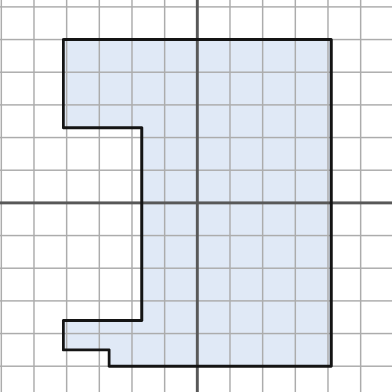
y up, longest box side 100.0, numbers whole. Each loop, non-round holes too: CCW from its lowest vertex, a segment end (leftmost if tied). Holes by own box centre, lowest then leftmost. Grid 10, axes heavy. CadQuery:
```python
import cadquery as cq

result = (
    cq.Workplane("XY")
    .moveTo(-27.0, -50.0)
    .lineTo(41.0, -50.0)
    .lineTo(41.0, 50.0)
    .lineTo(-41.0, 50.0)
    .lineTo(-41.0, 23.0)
    .lineTo(-17.0, 23.0)
    .lineTo(-17.0, -36.0)
    .lineTo(-41.0, -36.0)
    .lineTo(-41.0, -45.0)
    .lineTo(-27.0, -45.0)
    .close()
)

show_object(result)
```